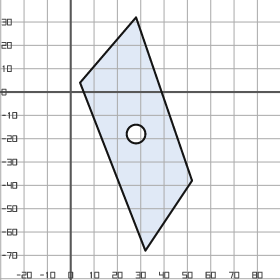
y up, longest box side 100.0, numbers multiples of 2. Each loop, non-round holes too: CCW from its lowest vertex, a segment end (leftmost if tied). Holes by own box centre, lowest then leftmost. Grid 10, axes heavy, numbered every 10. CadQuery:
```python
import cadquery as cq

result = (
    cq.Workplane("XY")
    .moveTo(32.0, -68.0)
    .lineTo(52.0, -38.0)
    .lineTo(28.0, 32.0)
    .lineTo(4.0, 4.0)
    .close()
    .moveTo(28.0, -18.0)
    .circle(4.0)
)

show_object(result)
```